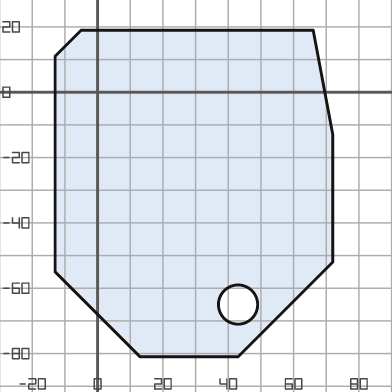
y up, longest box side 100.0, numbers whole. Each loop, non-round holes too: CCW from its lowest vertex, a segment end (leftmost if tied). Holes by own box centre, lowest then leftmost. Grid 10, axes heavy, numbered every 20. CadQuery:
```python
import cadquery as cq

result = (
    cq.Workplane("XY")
    .moveTo(13.0, -81.0)
    .lineTo(43.0, -81.0)
    .lineTo(72.0, -52.0)
    .lineTo(72.0, -13.0)
    .lineTo(66.0, 19.0)
    .lineTo(-5.0, 19.0)
    .lineTo(-13.0, 11.0)
    .lineTo(-13.0, -55.0)
    .close()
    .moveTo(43.0, -65.0)
    .circle(6.0)
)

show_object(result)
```